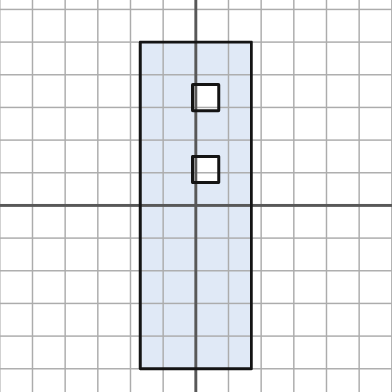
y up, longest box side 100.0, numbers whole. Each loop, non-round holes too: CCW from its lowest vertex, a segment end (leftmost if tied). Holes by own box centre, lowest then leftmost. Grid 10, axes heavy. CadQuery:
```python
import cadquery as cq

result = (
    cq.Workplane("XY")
    .moveTo(-17.0, -50.0)
    .lineTo(17.0, -50.0)
    .lineTo(17.0, 50.0)
    .lineTo(-17.0, 50.0)
    .close()
    .moveTo(-1.0, 7.0)
    .lineTo(7.0, 7.0)
    .lineTo(7.0, 15.0)
    .lineTo(-1.0, 15.0)
    .close()
    .moveTo(-1.0, 29.0)
    .lineTo(7.0, 29.0)
    .lineTo(7.0, 37.0)
    .lineTo(-1.0, 37.0)
    .close()
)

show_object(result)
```